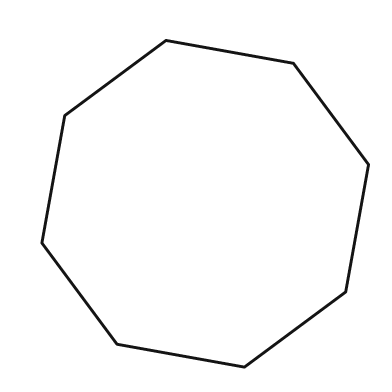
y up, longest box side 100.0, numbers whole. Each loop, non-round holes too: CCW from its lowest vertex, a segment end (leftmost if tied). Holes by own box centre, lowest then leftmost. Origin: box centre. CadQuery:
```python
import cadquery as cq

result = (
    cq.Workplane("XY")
    .moveTo(12.0, -50.0)
    .lineTo(43.0, -27.0)
    .lineTo(50.0, 12.0)
    .lineTo(27.0, 43.0)
    .lineTo(-12.0, 50.0)
    .lineTo(-43.0, 27.0)
    .lineTo(-50.0, -12.0)
    .lineTo(-27.0, -43.0)
    .close()
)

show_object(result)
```